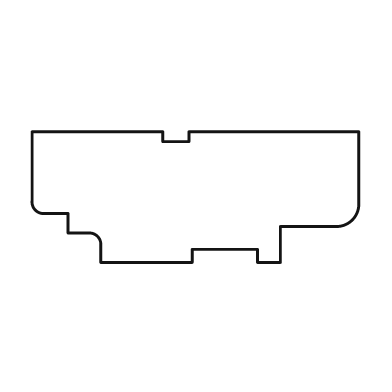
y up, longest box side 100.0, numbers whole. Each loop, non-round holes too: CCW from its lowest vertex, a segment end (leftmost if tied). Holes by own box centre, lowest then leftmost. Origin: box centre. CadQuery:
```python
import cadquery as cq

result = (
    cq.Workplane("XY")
    .moveTo(-29.0, -20.0)
    .lineTo(-1.0, -20.0)
    .lineTo(-1.0, -16.0)
    .lineTo(19.0, -16.0)
    .lineTo(19.0, -20.0)
    .lineTo(26.0, -20.0)
    .lineTo(26.0, -9.0)
    .lineTo(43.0, -9.0)
    .threePointArc((48.0, -7.0), (50.0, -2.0))
    .lineTo(50.0, 20.0)
    .lineTo(-2.0, 20.0)
    .lineTo(-2.0, 17.0)
    .lineTo(-10.0, 17.0)
    .lineTo(-10.0, 20.0)
    .lineTo(-50.0, 20.0)
    .lineTo(-50.0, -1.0)
    .threePointArc((-49.0, -4.0), (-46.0, -5.0))
    .lineTo(-39.0, -5.0)
    .lineTo(-39.0, -11.0)
    .lineTo(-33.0, -11.0)
    .threePointArc((-30.0, -12.0), (-29.0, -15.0))
    .close()
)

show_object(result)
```